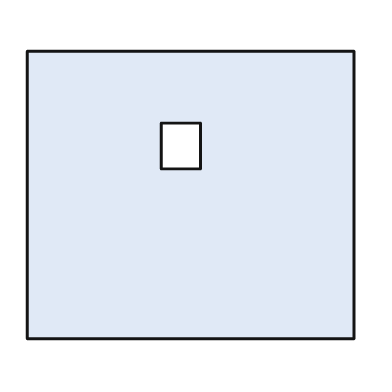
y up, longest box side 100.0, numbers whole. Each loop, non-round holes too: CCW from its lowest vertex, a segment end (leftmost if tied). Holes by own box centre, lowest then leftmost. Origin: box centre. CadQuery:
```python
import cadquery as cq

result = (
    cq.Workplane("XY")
    .moveTo(-50.0, -44.0)
    .lineTo(50.0, -44.0)
    .lineTo(50.0, 44.0)
    .lineTo(-50.0, 44.0)
    .close()
    .moveTo(-9.0, 8.0)
    .lineTo(3.0, 8.0)
    .lineTo(3.0, 22.0)
    .lineTo(-9.0, 22.0)
    .close()
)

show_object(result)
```